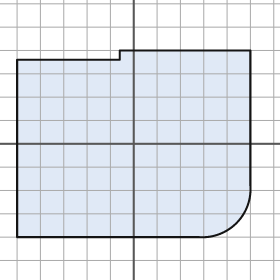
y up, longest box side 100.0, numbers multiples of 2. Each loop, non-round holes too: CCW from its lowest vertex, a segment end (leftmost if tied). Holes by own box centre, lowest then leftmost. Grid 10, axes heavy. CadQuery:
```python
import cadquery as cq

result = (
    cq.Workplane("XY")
    .moveTo(-50.0, -40.0)
    .lineTo(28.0, -40.0)
    .threePointArc((44.0, -34.0), (50.0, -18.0))
    .lineTo(50.0, 40.0)
    .lineTo(-6.0, 40.0)
    .lineTo(-6.0, 36.0)
    .lineTo(-50.0, 36.0)
    .close()
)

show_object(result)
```